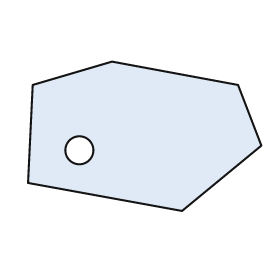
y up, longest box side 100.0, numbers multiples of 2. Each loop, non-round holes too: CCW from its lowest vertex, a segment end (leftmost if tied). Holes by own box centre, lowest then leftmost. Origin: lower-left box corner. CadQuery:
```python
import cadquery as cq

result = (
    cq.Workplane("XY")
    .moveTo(66.0, 0.0)
    .lineTo(100.0, 28.0)
    .lineTo(90.0, 54.0)
    .lineTo(36.0, 64.0)
    .lineTo(2.0, 54.0)
    .lineTo(0.0, 12.0)
    .close()
    .moveTo(22.0, 26.0)
    .circle(6.0)
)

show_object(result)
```